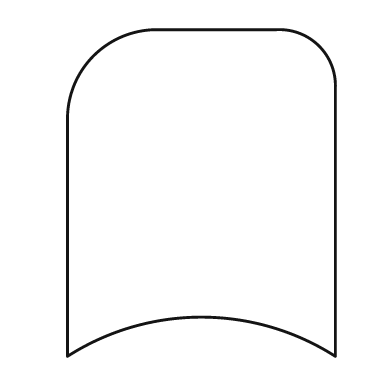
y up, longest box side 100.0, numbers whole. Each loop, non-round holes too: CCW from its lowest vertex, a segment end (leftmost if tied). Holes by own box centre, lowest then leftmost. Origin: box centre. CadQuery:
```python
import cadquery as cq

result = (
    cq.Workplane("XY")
    .moveTo(-41.0, -50.0)
    .threePointArc((0.0, -38.0), (41.0, -50.0))
    .lineTo(41.0, 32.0)
    .threePointArc((36.0, 45.0), (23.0, 50.0))
    .lineTo(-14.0, 50.0)
    .threePointArc((-33.0, 42.0), (-41.0, 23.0))
    .close()
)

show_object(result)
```